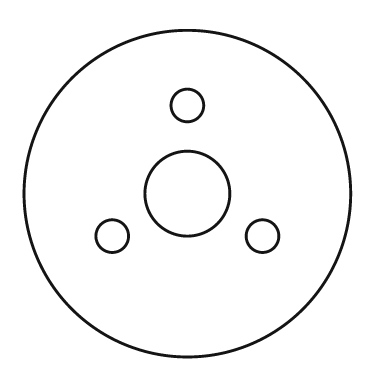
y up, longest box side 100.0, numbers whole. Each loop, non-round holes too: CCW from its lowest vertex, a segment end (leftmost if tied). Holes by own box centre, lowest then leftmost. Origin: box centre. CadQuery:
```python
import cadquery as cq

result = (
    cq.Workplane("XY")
    .moveTo(0.0, 0.0)
    .circle(50.0)
    .moveTo(-23.0, -13.0)
    .circle(5.0)
    .moveTo(23.0, -13.0)
    .circle(5.0)
    .moveTo(0.0, 0.0)
    .circle(13.0)
    .moveTo(0.0, 27.0)
    .circle(5.0)
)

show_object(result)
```